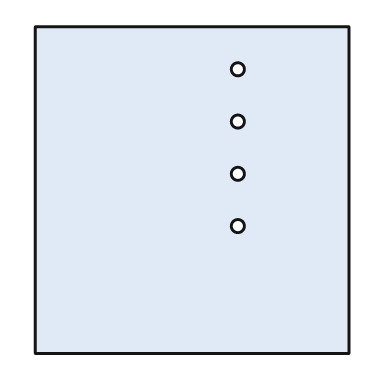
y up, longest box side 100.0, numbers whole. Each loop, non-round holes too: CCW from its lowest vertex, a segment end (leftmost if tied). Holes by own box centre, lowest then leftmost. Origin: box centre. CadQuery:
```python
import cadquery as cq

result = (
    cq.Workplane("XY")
    .moveTo(-48.0, -50.0)
    .lineTo(48.0, -50.0)
    .lineTo(48.0, 50.0)
    .lineTo(-48.0, 50.0)
    .close()
    .moveTo(14.0, -11.0)
    .circle(2.0)
    .moveTo(14.0, 5.0)
    .circle(2.0)
    .moveTo(14.0, 21.0)
    .circle(2.0)
    .moveTo(14.0, 37.0)
    .circle(2.0)
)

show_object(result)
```